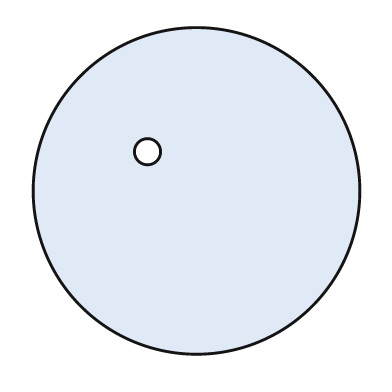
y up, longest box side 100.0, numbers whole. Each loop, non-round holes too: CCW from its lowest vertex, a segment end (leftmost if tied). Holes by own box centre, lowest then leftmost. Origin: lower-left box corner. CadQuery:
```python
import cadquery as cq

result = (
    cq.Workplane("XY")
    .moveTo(50.0, 50.0)
    .circle(50.0)
    .moveTo(35.0, 62.0)
    .circle(4.0)
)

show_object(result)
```